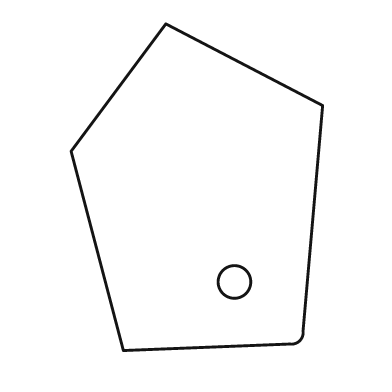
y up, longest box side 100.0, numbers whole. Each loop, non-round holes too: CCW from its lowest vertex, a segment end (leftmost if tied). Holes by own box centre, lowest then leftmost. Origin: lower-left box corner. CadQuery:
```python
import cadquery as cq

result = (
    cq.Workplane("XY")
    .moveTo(16.0, 0.0)
    .lineTo(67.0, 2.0)
    .threePointArc((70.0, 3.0), (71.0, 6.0))
    .lineTo(77.0, 75.0)
    .lineTo(29.0, 100.0)
    .lineTo(0.0, 61.0)
    .close()
    .moveTo(50.0, 21.0)
    .circle(5.0)
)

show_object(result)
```